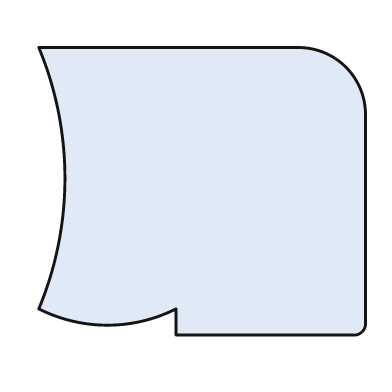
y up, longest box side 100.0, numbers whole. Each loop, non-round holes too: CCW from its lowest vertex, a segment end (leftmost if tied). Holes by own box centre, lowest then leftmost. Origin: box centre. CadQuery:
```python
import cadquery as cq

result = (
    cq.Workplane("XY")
    .moveTo(-8.0, -44.0)
    .lineTo(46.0, -44.0)
    .threePointArc((49.0, -43.0), (50.0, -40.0))
    .lineTo(50.0, 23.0)
    .threePointArc((44.0, 38.0), (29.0, 44.0))
    .lineTo(-50.0, 44.0)
    .threePointArc((-42.0, 4.0), (-50.0, -36.0))
    .threePointArc((-29.0, -41.0), (-8.0, -36.0))
    .close()
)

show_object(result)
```